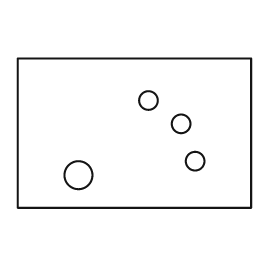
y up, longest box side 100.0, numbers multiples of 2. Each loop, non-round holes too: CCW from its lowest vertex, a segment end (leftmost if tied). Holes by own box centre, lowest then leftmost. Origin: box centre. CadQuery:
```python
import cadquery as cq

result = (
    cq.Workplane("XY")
    .moveTo(-50.0, -32.0)
    .lineTo(50.0, -32.0)
    .lineTo(50.0, 32.0)
    .lineTo(-50.0, 32.0)
    .close()
    .moveTo(-24.0, -18.0)
    .circle(6.0)
    .moveTo(26.0, -12.0)
    .circle(4.0)
    .moveTo(20.0, 4.0)
    .circle(4.0)
    .moveTo(6.0, 14.0)
    .circle(4.0)
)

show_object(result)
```